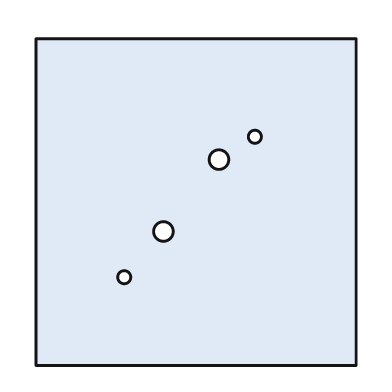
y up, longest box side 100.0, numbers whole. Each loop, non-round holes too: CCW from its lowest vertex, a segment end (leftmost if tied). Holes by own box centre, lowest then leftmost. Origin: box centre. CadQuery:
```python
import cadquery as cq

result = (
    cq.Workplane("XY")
    .moveTo(-49.0, -50.0)
    .lineTo(49.0, -50.0)
    .lineTo(49.0, 50.0)
    .lineTo(-49.0, 50.0)
    .close()
    .moveTo(-22.0, -23.0)
    .circle(2.0)
    .moveTo(-10.0, -9.0)
    .circle(3.0)
    .moveTo(7.0, 13.0)
    .circle(3.0)
    .moveTo(18.0, 20.0)
    .circle(2.0)
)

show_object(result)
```